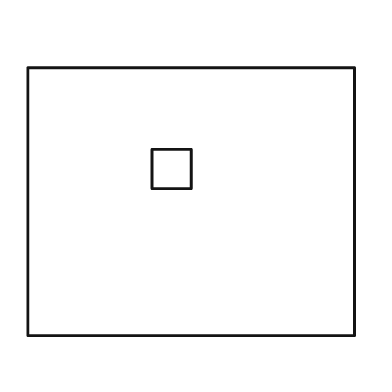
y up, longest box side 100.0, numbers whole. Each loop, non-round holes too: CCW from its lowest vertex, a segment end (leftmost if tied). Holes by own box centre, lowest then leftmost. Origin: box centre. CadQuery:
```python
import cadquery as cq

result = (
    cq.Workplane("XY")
    .moveTo(-50.0, -41.0)
    .lineTo(50.0, -41.0)
    .lineTo(50.0, 41.0)
    .lineTo(-50.0, 41.0)
    .close()
    .moveTo(-12.0, 4.0)
    .lineTo(0.0, 4.0)
    .lineTo(0.0, 16.0)
    .lineTo(-12.0, 16.0)
    .close()
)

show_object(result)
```